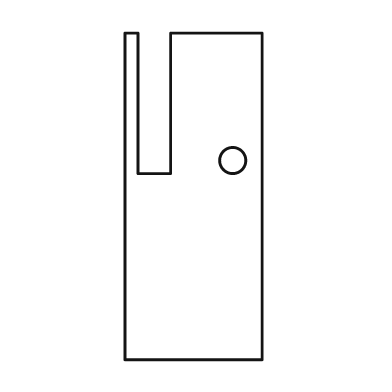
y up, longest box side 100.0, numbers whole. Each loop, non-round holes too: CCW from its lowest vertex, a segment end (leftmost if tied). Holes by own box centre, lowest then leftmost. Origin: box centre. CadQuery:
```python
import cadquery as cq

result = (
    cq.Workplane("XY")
    .moveTo(-21.0, -50.0)
    .lineTo(21.0, -50.0)
    .lineTo(21.0, 50.0)
    .lineTo(-7.0, 50.0)
    .lineTo(-7.0, 7.0)
    .lineTo(-17.0, 7.0)
    .lineTo(-17.0, 50.0)
    .lineTo(-21.0, 50.0)
    .close()
    .moveTo(12.0, 11.0)
    .circle(4.0)
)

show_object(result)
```